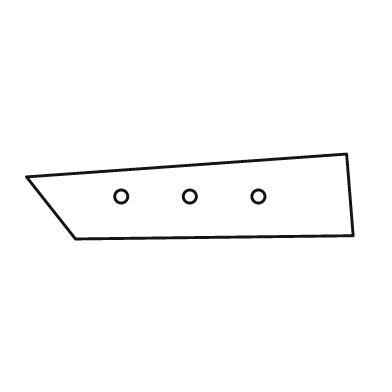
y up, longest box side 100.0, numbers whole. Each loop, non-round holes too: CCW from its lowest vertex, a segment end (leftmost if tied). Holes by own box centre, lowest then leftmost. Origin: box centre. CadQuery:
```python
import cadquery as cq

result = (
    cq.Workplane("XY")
    .moveTo(-35.0, -13.0)
    .lineTo(50.0, -12.0)
    .lineTo(48.0, 13.0)
    .lineTo(-50.0, 6.0)
    .close()
    .moveTo(-21.0, 0.0)
    .circle(2.0)
    .moveTo(0.0, 0.0)
    .circle(2.0)
    .moveTo(21.0, 0.0)
    .circle(2.0)
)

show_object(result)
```